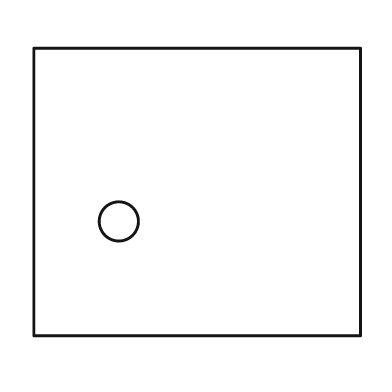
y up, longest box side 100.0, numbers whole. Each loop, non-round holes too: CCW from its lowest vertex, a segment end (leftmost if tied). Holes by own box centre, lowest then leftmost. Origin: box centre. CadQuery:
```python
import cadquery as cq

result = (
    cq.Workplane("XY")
    .moveTo(-50.0, -44.0)
    .lineTo(50.0, -44.0)
    .lineTo(50.0, 44.0)
    .lineTo(-50.0, 44.0)
    .close()
    .moveTo(-24.0, -9.0)
    .circle(6.0)
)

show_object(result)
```